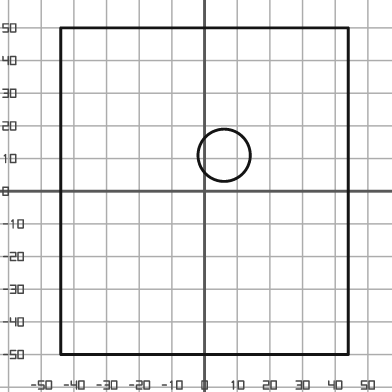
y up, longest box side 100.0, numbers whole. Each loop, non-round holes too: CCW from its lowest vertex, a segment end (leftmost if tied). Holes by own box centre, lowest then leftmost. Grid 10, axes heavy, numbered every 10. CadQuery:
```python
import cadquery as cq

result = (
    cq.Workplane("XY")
    .moveTo(-44.0, -50.0)
    .lineTo(44.0, -50.0)
    .lineTo(44.0, 50.0)
    .lineTo(-44.0, 50.0)
    .close()
    .moveTo(6.0, 11.0)
    .circle(8.0)
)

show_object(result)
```